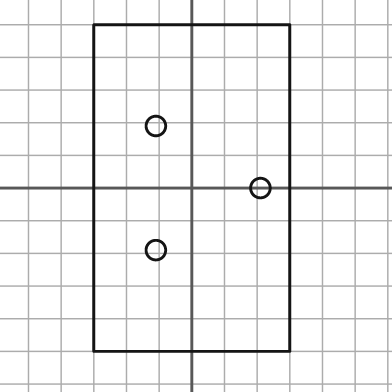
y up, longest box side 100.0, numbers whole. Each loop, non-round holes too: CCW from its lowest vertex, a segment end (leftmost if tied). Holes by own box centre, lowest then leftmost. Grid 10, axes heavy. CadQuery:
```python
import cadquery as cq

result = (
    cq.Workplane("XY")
    .moveTo(-30.0, -50.0)
    .lineTo(30.0, -50.0)
    .lineTo(30.0, 50.0)
    .lineTo(-30.0, 50.0)
    .close()
    .moveTo(-11.0, -19.0)
    .circle(3.0)
    .moveTo(21.0, 0.0)
    .circle(3.0)
    .moveTo(-11.0, 19.0)
    .circle(3.0)
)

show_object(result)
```